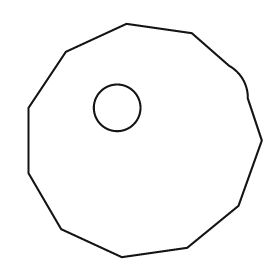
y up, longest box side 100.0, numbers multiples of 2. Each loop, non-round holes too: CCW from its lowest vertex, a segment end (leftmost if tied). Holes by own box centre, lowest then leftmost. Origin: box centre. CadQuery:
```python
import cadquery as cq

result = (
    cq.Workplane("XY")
    .moveTo(-10.0, -50.0)
    .lineTo(18.0, -46.0)
    .lineTo(40.0, -28.0)
    .lineTo(50.0, 0.0)
    .lineTo(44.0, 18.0)
    .threePointArc((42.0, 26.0), (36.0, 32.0))
    .lineTo(20.0, 46.0)
    .lineTo(-8.0, 50.0)
    .lineTo(-34.0, 38.0)
    .lineTo(-50.0, 14.0)
    .lineTo(-50.0, -14.0)
    .lineTo(-36.0, -38.0)
    .close()
    .moveTo(-12.0, 14.0)
    .circle(10.0)
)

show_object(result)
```